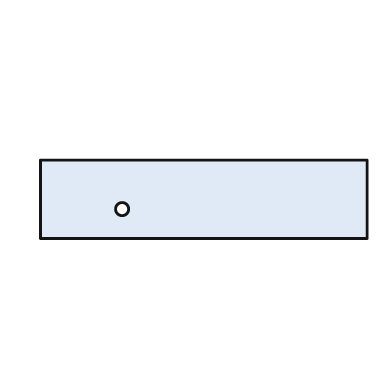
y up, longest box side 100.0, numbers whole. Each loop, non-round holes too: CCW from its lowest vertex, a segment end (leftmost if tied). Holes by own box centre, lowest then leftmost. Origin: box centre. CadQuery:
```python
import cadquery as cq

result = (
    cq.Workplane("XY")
    .moveTo(-50.0, -12.0)
    .lineTo(50.0, -12.0)
    .lineTo(50.0, 12.0)
    .lineTo(-50.0, 12.0)
    .close()
    .moveTo(-25.0, -3.0)
    .circle(2.0)
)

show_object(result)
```